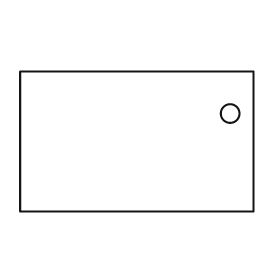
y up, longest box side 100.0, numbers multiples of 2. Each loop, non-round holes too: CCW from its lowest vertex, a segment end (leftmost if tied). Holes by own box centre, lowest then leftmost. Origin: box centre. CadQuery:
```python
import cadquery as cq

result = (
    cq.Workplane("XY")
    .moveTo(-50.0, -30.0)
    .lineTo(50.0, -30.0)
    .lineTo(50.0, 30.0)
    .lineTo(-50.0, 30.0)
    .close()
    .moveTo(40.0, 12.0)
    .circle(4.0)
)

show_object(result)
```